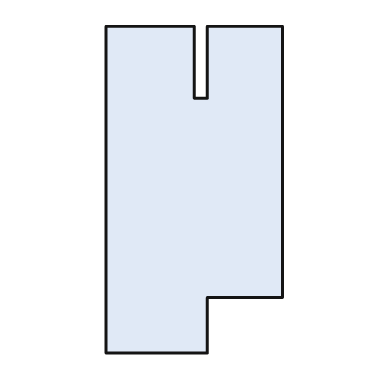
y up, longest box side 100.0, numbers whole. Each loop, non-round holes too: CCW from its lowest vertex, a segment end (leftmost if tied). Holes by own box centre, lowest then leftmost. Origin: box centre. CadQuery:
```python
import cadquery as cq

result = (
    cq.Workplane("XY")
    .moveTo(-27.0, -50.0)
    .lineTo(4.0, -50.0)
    .lineTo(4.0, -33.0)
    .lineTo(27.0, -33.0)
    .lineTo(27.0, 50.0)
    .lineTo(4.0, 50.0)
    .lineTo(4.0, 28.0)
    .lineTo(0.0, 28.0)
    .lineTo(0.0, 50.0)
    .lineTo(-27.0, 50.0)
    .close()
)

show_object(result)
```